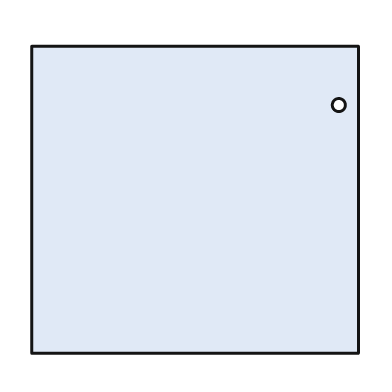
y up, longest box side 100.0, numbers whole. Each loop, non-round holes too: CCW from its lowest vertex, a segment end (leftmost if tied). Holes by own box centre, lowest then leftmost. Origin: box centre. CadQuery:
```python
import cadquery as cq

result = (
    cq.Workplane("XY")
    .moveTo(-50.0, -47.0)
    .lineTo(50.0, -47.0)
    .lineTo(50.0, 47.0)
    .lineTo(-50.0, 47.0)
    .close()
    .moveTo(44.0, 29.0)
    .circle(2.0)
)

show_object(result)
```